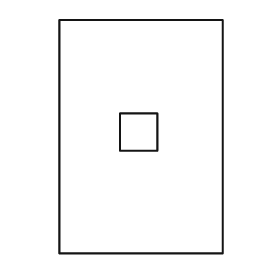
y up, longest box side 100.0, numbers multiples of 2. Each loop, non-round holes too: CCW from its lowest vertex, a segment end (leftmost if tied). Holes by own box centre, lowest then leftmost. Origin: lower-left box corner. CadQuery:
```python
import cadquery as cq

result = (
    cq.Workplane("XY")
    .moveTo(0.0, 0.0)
    .lineTo(70.0, 0.0)
    .lineTo(70.0, 100.0)
    .lineTo(0.0, 100.0)
    .close()
    .moveTo(26.0, 44.0)
    .lineTo(42.0, 44.0)
    .lineTo(42.0, 60.0)
    .lineTo(26.0, 60.0)
    .close()
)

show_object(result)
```